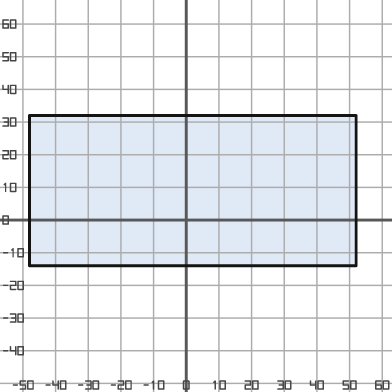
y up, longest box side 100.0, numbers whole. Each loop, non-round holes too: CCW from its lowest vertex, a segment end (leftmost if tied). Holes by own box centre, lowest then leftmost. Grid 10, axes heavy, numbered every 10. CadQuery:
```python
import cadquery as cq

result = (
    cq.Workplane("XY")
    .moveTo(-48.0, -14.0)
    .lineTo(52.0, -14.0)
    .lineTo(52.0, 32.0)
    .lineTo(-48.0, 32.0)
    .close()
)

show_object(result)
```